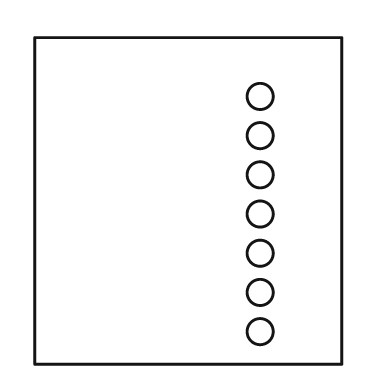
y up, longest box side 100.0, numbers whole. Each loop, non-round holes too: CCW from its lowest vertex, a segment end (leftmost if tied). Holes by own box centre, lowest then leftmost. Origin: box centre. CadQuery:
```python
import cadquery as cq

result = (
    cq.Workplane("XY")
    .moveTo(-47.0, -50.0)
    .lineTo(47.0, -50.0)
    .lineTo(47.0, 50.0)
    .lineTo(-47.0, 50.0)
    .close()
    .moveTo(22.0, -40.0)
    .circle(4.0)
    .moveTo(22.0, -28.0)
    .circle(4.0)
    .moveTo(22.0, -16.0)
    .circle(4.0)
    .moveTo(22.0, -4.0)
    .circle(4.0)
    .moveTo(22.0, 8.0)
    .circle(4.0)
    .moveTo(22.0, 20.0)
    .circle(4.0)
    .moveTo(22.0, 32.0)
    .circle(4.0)
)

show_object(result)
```